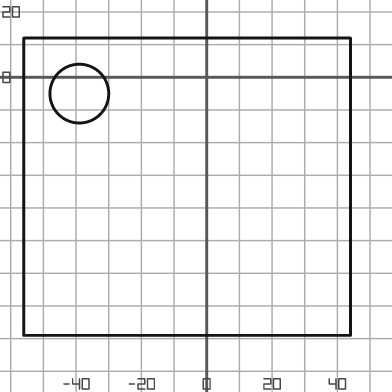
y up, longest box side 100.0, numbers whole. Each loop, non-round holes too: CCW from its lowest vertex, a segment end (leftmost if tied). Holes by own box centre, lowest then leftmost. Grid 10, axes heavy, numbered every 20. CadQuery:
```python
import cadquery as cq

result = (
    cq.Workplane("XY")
    .moveTo(-56.0, -79.0)
    .lineTo(44.0, -79.0)
    .lineTo(44.0, 12.0)
    .lineTo(-56.0, 12.0)
    .close()
    .moveTo(-39.0, -5.0)
    .circle(9.0)
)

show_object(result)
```